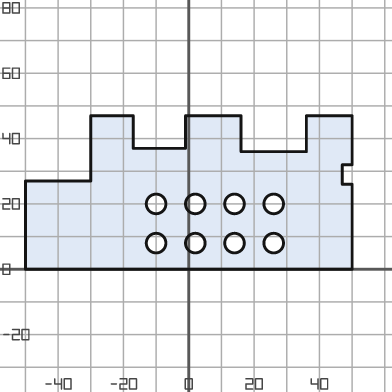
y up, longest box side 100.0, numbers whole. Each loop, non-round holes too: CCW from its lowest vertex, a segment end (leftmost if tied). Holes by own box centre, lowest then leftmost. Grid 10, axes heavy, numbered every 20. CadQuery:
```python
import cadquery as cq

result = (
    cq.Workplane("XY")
    .moveTo(-50.0, 0.0)
    .lineTo(50.0, 0.0)
    .lineTo(50.0, 26.0)
    .lineTo(47.0, 26.0)
    .lineTo(47.0, 32.0)
    .lineTo(50.0, 32.0)
    .lineTo(50.0, 47.0)
    .lineTo(36.0, 47.0)
    .lineTo(36.0, 36.0)
    .lineTo(16.0, 36.0)
    .lineTo(16.0, 47.0)
    .lineTo(-1.0, 47.0)
    .lineTo(-1.0, 37.0)
    .lineTo(-17.0, 37.0)
    .lineTo(-17.0, 47.0)
    .lineTo(-30.0, 47.0)
    .lineTo(-30.0, 27.0)
    .lineTo(-50.0, 27.0)
    .close()
    .moveTo(-10.0, 8.0)
    .circle(3.0)
    .moveTo(2.0, 8.0)
    .circle(3.0)
    .moveTo(14.0, 8.0)
    .circle(3.0)
    .moveTo(26.0, 8.0)
    .circle(3.0)
    .moveTo(-10.0, 20.0)
    .circle(3.0)
    .moveTo(2.0, 20.0)
    .circle(3.0)
    .moveTo(14.0, 20.0)
    .circle(3.0)
    .moveTo(26.0, 20.0)
    .circle(3.0)
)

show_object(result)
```